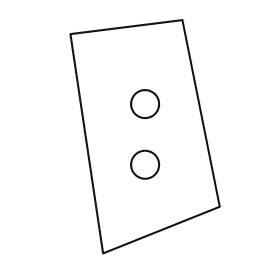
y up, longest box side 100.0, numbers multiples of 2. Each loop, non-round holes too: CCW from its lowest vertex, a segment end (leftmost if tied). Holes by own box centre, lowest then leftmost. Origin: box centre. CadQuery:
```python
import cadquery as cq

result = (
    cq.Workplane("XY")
    .moveTo(-18.0, -50.0)
    .lineTo(32.0, -30.0)
    .lineTo(16.0, 50.0)
    .lineTo(-32.0, 44.0)
    .close()
    .moveTo(0.0, -12.0)
    .circle(6.0)
    .moveTo(0.0, 14.0)
    .circle(6.0)
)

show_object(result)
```